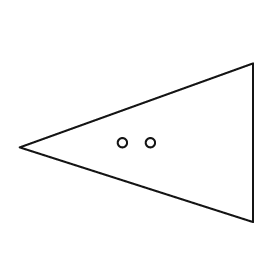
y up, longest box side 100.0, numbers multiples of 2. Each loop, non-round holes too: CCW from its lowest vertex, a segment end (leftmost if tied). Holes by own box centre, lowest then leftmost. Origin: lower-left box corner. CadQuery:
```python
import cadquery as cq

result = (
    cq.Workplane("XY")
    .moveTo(100.0, 0.0)
    .lineTo(100.0, 68.0)
    .lineTo(0.0, 32.0)
    .close()
    .moveTo(44.0, 34.0)
    .circle(2.0)
    .moveTo(56.0, 34.0)
    .circle(2.0)
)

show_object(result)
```